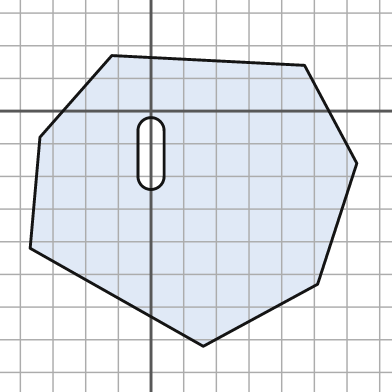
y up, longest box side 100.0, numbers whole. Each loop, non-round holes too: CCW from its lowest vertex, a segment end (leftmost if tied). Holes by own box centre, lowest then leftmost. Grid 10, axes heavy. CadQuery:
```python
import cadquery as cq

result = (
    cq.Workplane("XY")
    .moveTo(16.0, -72.0)
    .lineTo(51.0, -53.0)
    .lineTo(63.0, -16.0)
    .lineTo(47.0, 14.0)
    .lineTo(-12.0, 17.0)
    .lineTo(-34.0, -8.0)
    .lineTo(-37.0, -42.0)
    .close()
    .moveTo(-4.0, -20.0)
    .threePointArc((0.0, -24.0), (4.0, -20.0))
    .lineTo(4.0, -6.0)
    .threePointArc((0.0, -2.0), (-4.0, -6.0))
    .close()
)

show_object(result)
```